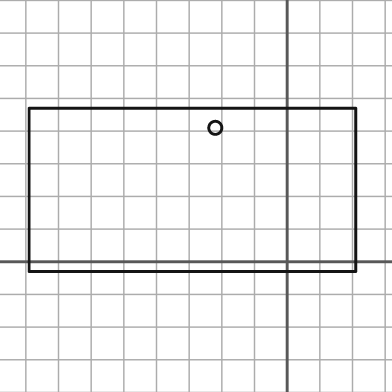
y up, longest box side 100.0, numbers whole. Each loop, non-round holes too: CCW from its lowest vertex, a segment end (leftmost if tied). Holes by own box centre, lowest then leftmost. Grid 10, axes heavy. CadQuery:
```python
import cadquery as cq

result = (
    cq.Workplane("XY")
    .moveTo(-79.0, -3.0)
    .lineTo(21.0, -3.0)
    .lineTo(21.0, 47.0)
    .lineTo(-79.0, 47.0)
    .close()
    .moveTo(-22.0, 41.0)
    .circle(2.0)
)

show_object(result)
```